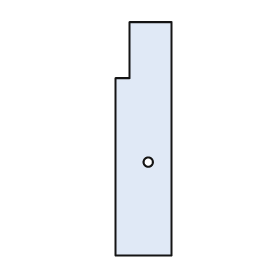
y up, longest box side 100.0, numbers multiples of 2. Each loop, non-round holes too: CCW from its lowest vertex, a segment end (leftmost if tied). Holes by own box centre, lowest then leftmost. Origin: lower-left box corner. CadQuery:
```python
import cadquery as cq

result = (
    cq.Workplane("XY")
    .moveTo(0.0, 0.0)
    .lineTo(24.0, 0.0)
    .lineTo(24.0, 100.0)
    .lineTo(6.0, 100.0)
    .lineTo(6.0, 76.0)
    .lineTo(0.0, 76.0)
    .close()
    .moveTo(14.0, 40.0)
    .circle(2.0)
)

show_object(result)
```